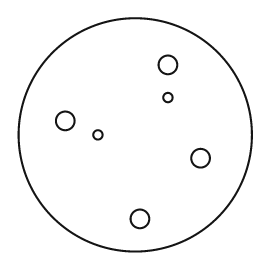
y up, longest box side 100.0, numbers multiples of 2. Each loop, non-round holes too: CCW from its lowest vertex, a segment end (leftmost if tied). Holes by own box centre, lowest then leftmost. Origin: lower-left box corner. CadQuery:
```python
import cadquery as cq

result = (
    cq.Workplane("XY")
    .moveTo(50.0, 50.0)
    .circle(50.0)
    .moveTo(52.0, 14.0)
    .circle(4.0)
    .moveTo(78.0, 40.0)
    .circle(4.0)
    .moveTo(34.0, 50.0)
    .circle(2.0)
    .moveTo(20.0, 56.0)
    .circle(4.0)
    .moveTo(64.0, 66.0)
    .circle(2.0)
    .moveTo(64.0, 80.0)
    .circle(4.0)
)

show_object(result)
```